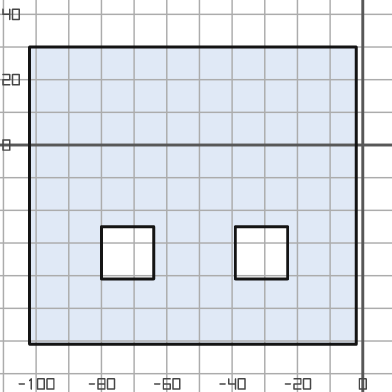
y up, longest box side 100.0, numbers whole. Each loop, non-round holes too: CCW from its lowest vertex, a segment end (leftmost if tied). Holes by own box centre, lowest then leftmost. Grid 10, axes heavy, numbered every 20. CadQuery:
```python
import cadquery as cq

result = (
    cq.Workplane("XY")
    .moveTo(-102.0, -61.0)
    .lineTo(-2.0, -61.0)
    .lineTo(-2.0, 30.0)
    .lineTo(-102.0, 30.0)
    .close()
    .moveTo(-80.0, -41.0)
    .lineTo(-64.0, -41.0)
    .lineTo(-64.0, -25.0)
    .lineTo(-80.0, -25.0)
    .close()
    .moveTo(-39.0, -41.0)
    .lineTo(-23.0, -41.0)
    .lineTo(-23.0, -25.0)
    .lineTo(-39.0, -25.0)
    .close()
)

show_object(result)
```